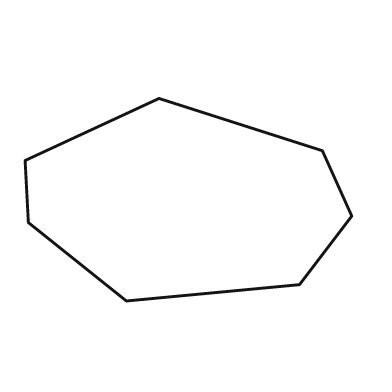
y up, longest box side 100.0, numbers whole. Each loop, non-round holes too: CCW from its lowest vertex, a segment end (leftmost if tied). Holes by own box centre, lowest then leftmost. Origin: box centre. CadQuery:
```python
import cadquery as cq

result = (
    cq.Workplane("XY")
    .moveTo(-19.0, -31.0)
    .lineTo(34.0, -26.0)
    .lineTo(50.0, -5.0)
    .lineTo(41.0, 15.0)
    .lineTo(-9.0, 31.0)
    .lineTo(-50.0, 12.0)
    .lineTo(-49.0, -7.0)
    .close()
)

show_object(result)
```